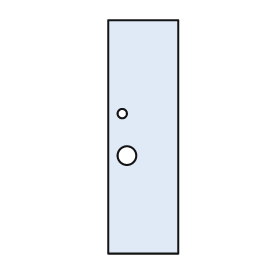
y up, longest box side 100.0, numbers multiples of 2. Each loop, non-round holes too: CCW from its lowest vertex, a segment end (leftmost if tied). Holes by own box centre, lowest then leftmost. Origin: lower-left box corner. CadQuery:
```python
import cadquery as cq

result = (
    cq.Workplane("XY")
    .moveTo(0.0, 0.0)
    .lineTo(30.0, 0.0)
    .lineTo(30.0, 100.0)
    .lineTo(0.0, 100.0)
    .close()
    .moveTo(8.0, 42.0)
    .circle(4.0)
    .moveTo(6.0, 60.0)
    .circle(2.0)
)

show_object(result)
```